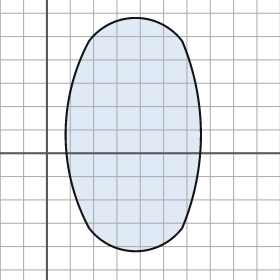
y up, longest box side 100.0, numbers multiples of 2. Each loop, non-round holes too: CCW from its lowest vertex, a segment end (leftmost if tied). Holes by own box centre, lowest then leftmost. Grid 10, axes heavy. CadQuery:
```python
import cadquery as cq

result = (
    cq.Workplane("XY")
    .moveTo(18.0, -32.0)
    .threePointArc((38.0, -42.0), (58.0, -32.0))
    .threePointArc((66.0, 8.0), (58.0, 48.0))
    .threePointArc((38.0, 58.0), (18.0, 48.0))
    .threePointArc((8.0, 8.0), (18.0, -32.0))
    .close()
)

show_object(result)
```